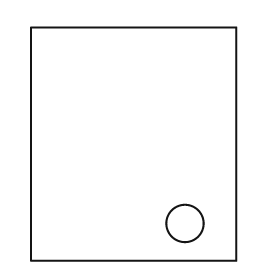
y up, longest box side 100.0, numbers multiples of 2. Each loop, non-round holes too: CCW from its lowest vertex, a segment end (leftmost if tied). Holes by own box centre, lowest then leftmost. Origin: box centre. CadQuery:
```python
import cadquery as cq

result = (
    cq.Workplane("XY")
    .moveTo(-44.0, -50.0)
    .lineTo(44.0, -50.0)
    .lineTo(44.0, 50.0)
    .lineTo(-44.0, 50.0)
    .close()
    .moveTo(22.0, -34.0)
    .circle(8.0)
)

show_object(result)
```